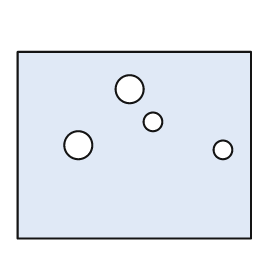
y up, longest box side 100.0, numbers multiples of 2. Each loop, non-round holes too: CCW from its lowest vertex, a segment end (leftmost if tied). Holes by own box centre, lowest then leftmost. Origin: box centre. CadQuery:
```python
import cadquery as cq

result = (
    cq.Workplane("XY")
    .moveTo(-50.0, -40.0)
    .lineTo(50.0, -40.0)
    .lineTo(50.0, 40.0)
    .lineTo(-50.0, 40.0)
    .close()
    .moveTo(38.0, -2.0)
    .circle(4.0)
    .moveTo(-24.0, 0.0)
    .circle(6.0)
    .moveTo(8.0, 10.0)
    .circle(4.0)
    .moveTo(-2.0, 24.0)
    .circle(6.0)
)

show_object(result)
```